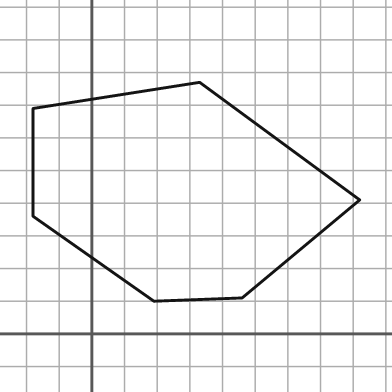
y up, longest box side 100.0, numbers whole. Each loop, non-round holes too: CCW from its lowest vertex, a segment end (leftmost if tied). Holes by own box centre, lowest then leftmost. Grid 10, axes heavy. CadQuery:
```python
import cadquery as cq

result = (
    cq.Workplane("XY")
    .moveTo(19.0, 10.0)
    .lineTo(46.0, 11.0)
    .lineTo(82.0, 41.0)
    .lineTo(33.0, 77.0)
    .lineTo(-18.0, 69.0)
    .lineTo(-18.0, 36.0)
    .close()
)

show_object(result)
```